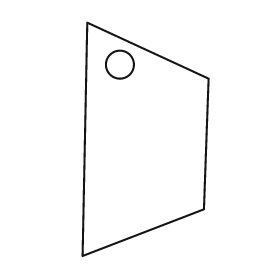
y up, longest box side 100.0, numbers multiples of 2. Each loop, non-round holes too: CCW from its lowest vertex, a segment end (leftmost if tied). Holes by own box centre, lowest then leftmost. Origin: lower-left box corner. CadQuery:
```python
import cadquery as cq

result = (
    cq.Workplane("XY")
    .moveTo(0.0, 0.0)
    .lineTo(52.0, 20.0)
    .lineTo(54.0, 76.0)
    .lineTo(2.0, 100.0)
    .close()
    .moveTo(16.0, 82.0)
    .circle(6.0)
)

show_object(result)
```